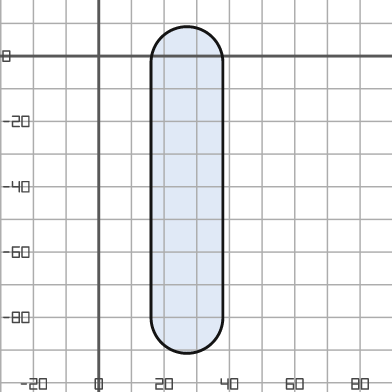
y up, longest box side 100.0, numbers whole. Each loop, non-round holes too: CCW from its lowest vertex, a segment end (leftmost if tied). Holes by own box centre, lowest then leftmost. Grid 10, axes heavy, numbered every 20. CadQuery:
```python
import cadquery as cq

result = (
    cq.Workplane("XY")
    .moveTo(16.0, -80.0)
    .threePointArc((27.0, -91.0), (38.0, -80.0))
    .lineTo(38.0, -2.0)
    .threePointArc((27.0, 9.0), (16.0, -2.0))
    .close()
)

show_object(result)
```